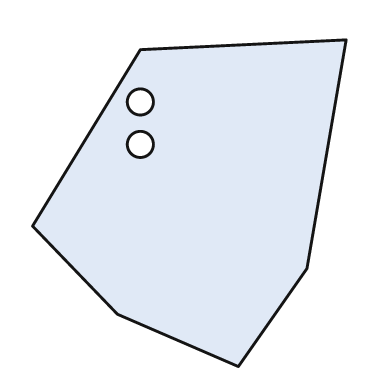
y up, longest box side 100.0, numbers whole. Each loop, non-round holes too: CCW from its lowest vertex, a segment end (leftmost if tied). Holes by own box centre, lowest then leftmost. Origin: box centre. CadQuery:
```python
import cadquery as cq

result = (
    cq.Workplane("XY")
    .moveTo(15.0, -50.0)
    .lineTo(36.0, -20.0)
    .lineTo(48.0, 50.0)
    .lineTo(-15.0, 47.0)
    .lineTo(-48.0, -7.0)
    .lineTo(-22.0, -34.0)
    .close()
    .moveTo(-15.0, 18.0)
    .circle(4.0)
    .moveTo(-15.0, 31.0)
    .circle(4.0)
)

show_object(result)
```